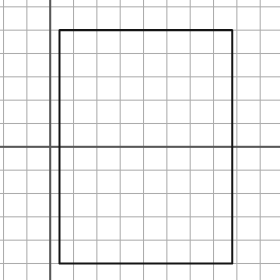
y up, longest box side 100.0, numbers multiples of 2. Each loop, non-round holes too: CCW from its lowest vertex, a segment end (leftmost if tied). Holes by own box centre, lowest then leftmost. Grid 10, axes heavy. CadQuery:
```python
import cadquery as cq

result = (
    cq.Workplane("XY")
    .moveTo(4.0, -50.0)
    .lineTo(78.0, -50.0)
    .lineTo(78.0, 50.0)
    .lineTo(4.0, 50.0)
    .close()
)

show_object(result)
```